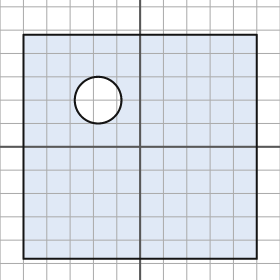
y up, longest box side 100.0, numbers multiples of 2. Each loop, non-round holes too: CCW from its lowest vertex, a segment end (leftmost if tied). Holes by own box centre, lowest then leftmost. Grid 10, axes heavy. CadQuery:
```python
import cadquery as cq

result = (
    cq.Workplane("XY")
    .moveTo(-50.0, -48.0)
    .lineTo(50.0, -48.0)
    .lineTo(50.0, 48.0)
    .lineTo(-50.0, 48.0)
    .close()
    .moveTo(-18.0, 20.0)
    .circle(10.0)
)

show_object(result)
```